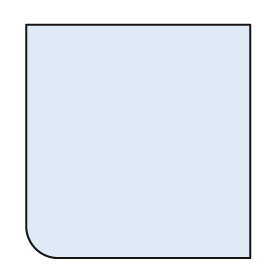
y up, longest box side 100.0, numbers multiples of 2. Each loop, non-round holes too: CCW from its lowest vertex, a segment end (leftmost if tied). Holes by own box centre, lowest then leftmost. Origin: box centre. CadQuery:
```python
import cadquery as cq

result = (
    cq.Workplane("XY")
    .moveTo(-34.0, -50.0)
    .lineTo(48.0, -50.0)
    .lineTo(48.0, 50.0)
    .lineTo(-48.0, 50.0)
    .lineTo(-48.0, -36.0)
    .threePointArc((-44.0, -46.0), (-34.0, -50.0))
    .close()
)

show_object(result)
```